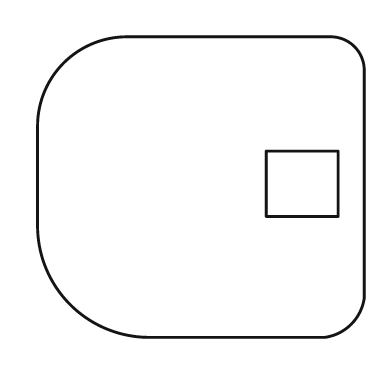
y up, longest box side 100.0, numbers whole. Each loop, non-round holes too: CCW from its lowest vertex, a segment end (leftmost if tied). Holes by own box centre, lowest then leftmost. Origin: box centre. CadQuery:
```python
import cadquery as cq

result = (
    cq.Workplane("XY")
    .moveTo(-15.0, -46.0)
    .lineTo(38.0, -46.0)
    .threePointArc((46.0, -42.0), (50.0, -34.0))
    .lineTo(50.0, 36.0)
    .threePointArc((47.0, 43.0), (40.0, 46.0))
    .lineTo(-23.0, 46.0)
    .threePointArc((-42.0, 38.0), (-50.0, 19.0))
    .lineTo(-50.0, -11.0)
    .threePointArc((-40.0, -36.0), (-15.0, -46.0))
    .close()
    .moveTo(20.0, -9.0)
    .lineTo(42.0, -9.0)
    .lineTo(42.0, 11.0)
    .lineTo(20.0, 11.0)
    .close()
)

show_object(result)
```